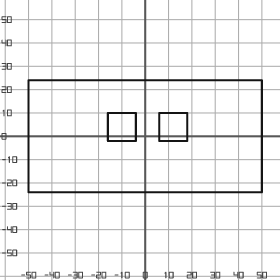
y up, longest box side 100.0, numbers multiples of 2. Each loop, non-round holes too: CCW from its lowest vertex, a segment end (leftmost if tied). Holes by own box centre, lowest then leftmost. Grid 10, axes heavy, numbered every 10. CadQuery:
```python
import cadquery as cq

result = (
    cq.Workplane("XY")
    .moveTo(-50.0, -24.0)
    .lineTo(50.0, -24.0)
    .lineTo(50.0, 24.0)
    .lineTo(-50.0, 24.0)
    .close()
    .moveTo(-16.0, -2.0)
    .lineTo(-4.0, -2.0)
    .lineTo(-4.0, 10.0)
    .lineTo(-16.0, 10.0)
    .close()
    .moveTo(6.0, -2.0)
    .lineTo(18.0, -2.0)
    .lineTo(18.0, 10.0)
    .lineTo(6.0, 10.0)
    .close()
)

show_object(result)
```